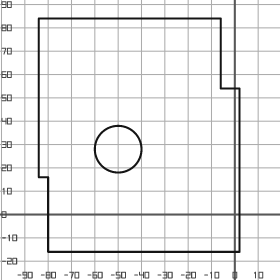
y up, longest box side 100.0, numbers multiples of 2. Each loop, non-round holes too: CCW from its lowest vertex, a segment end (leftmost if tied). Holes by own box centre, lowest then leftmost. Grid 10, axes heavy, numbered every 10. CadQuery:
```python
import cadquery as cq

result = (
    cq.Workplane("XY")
    .moveTo(-80.0, -16.0)
    .lineTo(2.0, -16.0)
    .lineTo(2.0, 54.0)
    .lineTo(-6.0, 54.0)
    .lineTo(-6.0, 84.0)
    .lineTo(-84.0, 84.0)
    .lineTo(-84.0, 16.0)
    .lineTo(-80.0, 16.0)
    .close()
    .moveTo(-50.0, 28.0)
    .circle(10.0)
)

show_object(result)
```